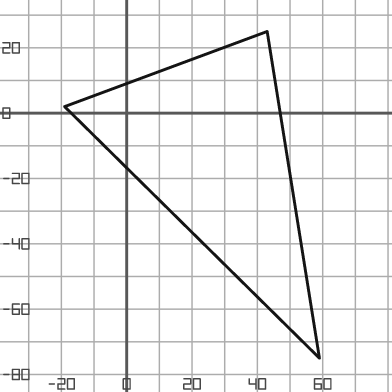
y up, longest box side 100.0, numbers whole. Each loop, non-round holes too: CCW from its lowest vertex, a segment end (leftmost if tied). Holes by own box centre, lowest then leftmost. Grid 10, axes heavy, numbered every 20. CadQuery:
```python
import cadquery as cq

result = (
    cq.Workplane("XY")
    .moveTo(59.0, -75.0)
    .lineTo(43.0, 25.0)
    .lineTo(-19.0, 2.0)
    .close()
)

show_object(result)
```